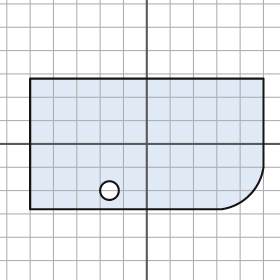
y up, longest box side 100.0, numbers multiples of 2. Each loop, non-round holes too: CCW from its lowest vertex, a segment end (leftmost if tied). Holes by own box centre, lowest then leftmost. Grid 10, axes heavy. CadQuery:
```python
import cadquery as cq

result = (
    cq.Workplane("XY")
    .moveTo(-50.0, -28.0)
    .lineTo(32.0, -28.0)
    .threePointArc((44.0, -22.0), (50.0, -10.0))
    .lineTo(50.0, 28.0)
    .lineTo(-50.0, 28.0)
    .close()
    .moveTo(-16.0, -20.0)
    .circle(4.0)
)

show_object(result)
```